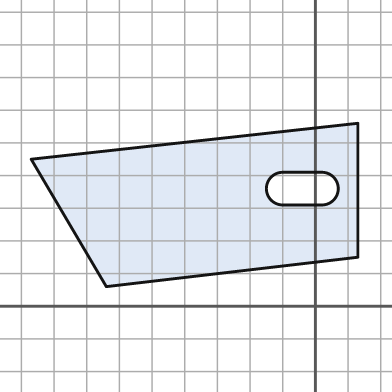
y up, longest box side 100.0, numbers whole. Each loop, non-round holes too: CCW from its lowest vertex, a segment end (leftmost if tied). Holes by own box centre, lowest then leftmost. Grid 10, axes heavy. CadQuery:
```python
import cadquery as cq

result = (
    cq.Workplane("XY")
    .moveTo(-64.0, 6.0)
    .lineTo(13.0, 15.0)
    .lineTo(13.0, 56.0)
    .lineTo(-87.0, 45.0)
    .close()
    .moveTo(-10.0, 31.0)
    .lineTo(2.0, 31.0)
    .threePointArc((7.0, 36.0), (2.0, 41.0))
    .lineTo(-10.0, 41.0)
    .threePointArc((-15.0, 36.0), (-10.0, 31.0))
    .close()
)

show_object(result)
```